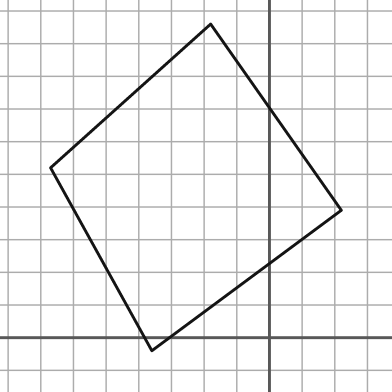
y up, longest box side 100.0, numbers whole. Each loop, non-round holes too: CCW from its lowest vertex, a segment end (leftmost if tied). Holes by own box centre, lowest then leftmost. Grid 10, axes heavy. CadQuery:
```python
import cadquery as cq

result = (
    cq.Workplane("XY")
    .moveTo(-36.0, -4.0)
    .lineTo(22.0, 39.0)
    .lineTo(-18.0, 96.0)
    .lineTo(-67.0, 52.0)
    .close()
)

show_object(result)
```